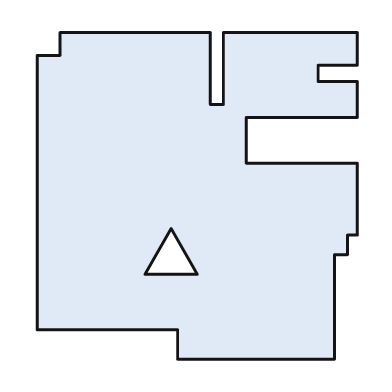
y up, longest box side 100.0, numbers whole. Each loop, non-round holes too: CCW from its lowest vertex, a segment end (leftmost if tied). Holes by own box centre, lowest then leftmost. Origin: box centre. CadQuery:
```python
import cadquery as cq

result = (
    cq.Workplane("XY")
    .moveTo(-6.0, -50.0)
    .lineTo(42.0, -50.0)
    .lineTo(42.0, -18.0)
    .lineTo(46.0, -18.0)
    .lineTo(46.0, -12.0)
    .lineTo(49.0, -12.0)
    .lineTo(49.0, 10.0)
    .lineTo(15.0, 10.0)
    .lineTo(15.0, 24.0)
    .lineTo(49.0, 24.0)
    .lineTo(49.0, 35.0)
    .lineTo(37.0, 35.0)
    .lineTo(37.0, 40.0)
    .lineTo(49.0, 40.0)
    .lineTo(49.0, 50.0)
    .lineTo(8.0, 50.0)
    .lineTo(8.0, 28.0)
    .lineTo(4.0, 28.0)
    .lineTo(4.0, 50.0)
    .lineTo(-42.0, 50.0)
    .lineTo(-42.0, 43.0)
    .lineTo(-49.0, 43.0)
    .lineTo(-49.0, -41.0)
    .lineTo(-6.0, -41.0)
    .close()
    .moveTo(-16.0, -24.0)
    .lineTo(0.0, -24.0)
    .lineTo(-8.0, -10.0)
    .close()
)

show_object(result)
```